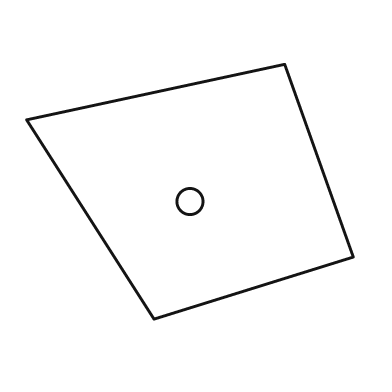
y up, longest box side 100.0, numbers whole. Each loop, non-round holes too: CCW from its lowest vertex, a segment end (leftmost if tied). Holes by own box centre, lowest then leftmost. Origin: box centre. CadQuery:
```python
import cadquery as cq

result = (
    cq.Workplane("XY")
    .moveTo(-11.0, -39.0)
    .lineTo(50.0, -20.0)
    .lineTo(29.0, 39.0)
    .lineTo(-50.0, 22.0)
    .close()
    .moveTo(0.0, -3.0)
    .circle(4.0)
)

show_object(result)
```